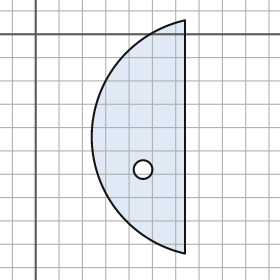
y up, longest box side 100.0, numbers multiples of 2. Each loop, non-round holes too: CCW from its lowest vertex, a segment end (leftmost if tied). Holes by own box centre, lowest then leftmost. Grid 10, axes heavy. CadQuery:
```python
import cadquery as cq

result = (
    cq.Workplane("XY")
    .moveTo(64.0, -94.0)
    .lineTo(64.0, 6.0)
    .threePointArc((24.0, -44.0), (64.0, -94.0))
    .close()
    .moveTo(46.0, -58.0)
    .circle(4.0)
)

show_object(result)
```